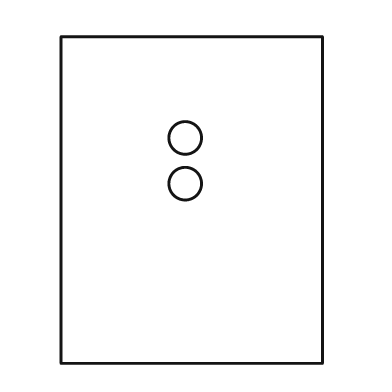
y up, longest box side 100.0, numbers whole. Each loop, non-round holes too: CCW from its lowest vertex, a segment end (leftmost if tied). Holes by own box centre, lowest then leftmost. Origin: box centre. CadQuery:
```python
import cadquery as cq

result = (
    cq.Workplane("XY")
    .moveTo(-40.0, -50.0)
    .lineTo(40.0, -50.0)
    .lineTo(40.0, 50.0)
    .lineTo(-40.0, 50.0)
    .close()
    .moveTo(-2.0, 5.0)
    .circle(5.0)
    .moveTo(-2.0, 19.0)
    .circle(5.0)
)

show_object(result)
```